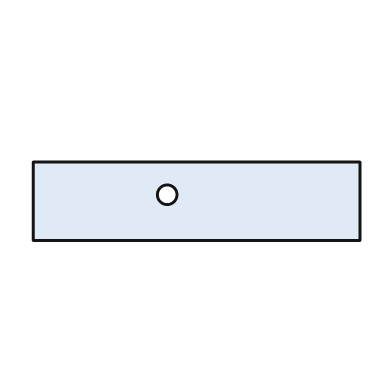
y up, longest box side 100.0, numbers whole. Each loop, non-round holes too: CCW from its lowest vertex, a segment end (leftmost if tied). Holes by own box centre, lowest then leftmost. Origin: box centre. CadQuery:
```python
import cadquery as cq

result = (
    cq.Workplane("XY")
    .moveTo(-50.0, -12.0)
    .lineTo(50.0, -12.0)
    .lineTo(50.0, 12.0)
    .lineTo(-50.0, 12.0)
    .close()
    .moveTo(-9.0, 2.0)
    .circle(3.0)
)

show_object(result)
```